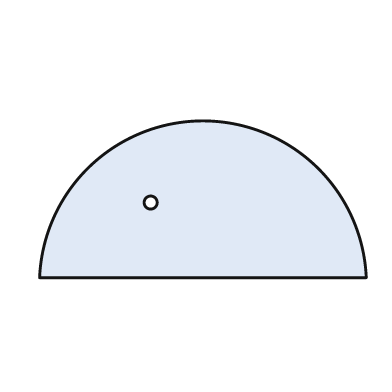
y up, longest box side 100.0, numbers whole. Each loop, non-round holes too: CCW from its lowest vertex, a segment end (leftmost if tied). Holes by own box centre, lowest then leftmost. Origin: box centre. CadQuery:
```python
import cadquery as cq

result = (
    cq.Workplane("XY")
    .moveTo(-50.0, -24.0)
    .lineTo(50.0, -24.0)
    .threePointArc((0.0, 24.0), (-50.0, -24.0))
    .close()
    .moveTo(-16.0, -1.0)
    .circle(2.0)
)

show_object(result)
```